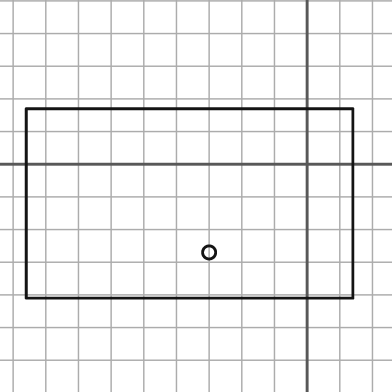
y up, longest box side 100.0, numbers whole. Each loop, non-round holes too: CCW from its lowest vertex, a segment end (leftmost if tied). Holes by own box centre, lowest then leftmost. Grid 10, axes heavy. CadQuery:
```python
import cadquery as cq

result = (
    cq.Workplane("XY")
    .moveTo(-86.0, -41.0)
    .lineTo(14.0, -41.0)
    .lineTo(14.0, 17.0)
    .lineTo(-86.0, 17.0)
    .close()
    .moveTo(-30.0, -27.0)
    .circle(2.0)
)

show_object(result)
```